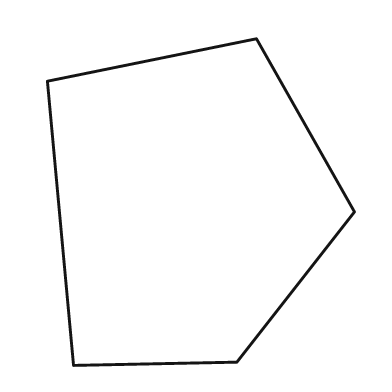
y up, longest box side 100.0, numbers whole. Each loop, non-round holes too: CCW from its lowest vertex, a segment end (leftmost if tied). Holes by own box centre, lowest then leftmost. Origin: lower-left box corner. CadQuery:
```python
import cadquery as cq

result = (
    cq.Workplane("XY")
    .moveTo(8.0, 0.0)
    .lineTo(58.0, 1.0)
    .lineTo(94.0, 47.0)
    .lineTo(64.0, 100.0)
    .lineTo(0.0, 87.0)
    .close()
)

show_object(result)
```